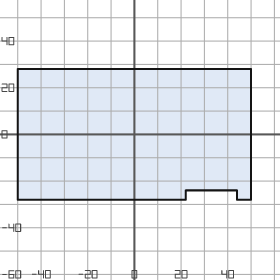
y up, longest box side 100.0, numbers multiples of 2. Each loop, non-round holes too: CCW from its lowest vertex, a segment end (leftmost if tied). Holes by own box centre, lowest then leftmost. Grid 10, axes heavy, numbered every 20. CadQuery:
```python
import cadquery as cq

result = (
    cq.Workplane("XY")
    .moveTo(-50.0, -28.0)
    .lineTo(22.0, -28.0)
    .lineTo(22.0, -24.0)
    .lineTo(44.0, -24.0)
    .lineTo(44.0, -28.0)
    .lineTo(50.0, -28.0)
    .lineTo(50.0, 28.0)
    .lineTo(-50.0, 28.0)
    .close()
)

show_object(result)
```